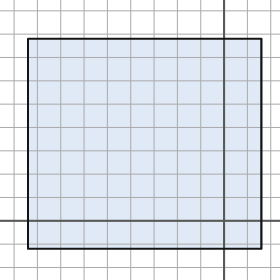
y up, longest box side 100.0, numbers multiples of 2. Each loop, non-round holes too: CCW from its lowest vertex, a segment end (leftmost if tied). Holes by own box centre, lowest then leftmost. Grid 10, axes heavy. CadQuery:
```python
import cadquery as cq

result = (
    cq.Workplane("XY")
    .moveTo(-84.0, -12.0)
    .lineTo(16.0, -12.0)
    .lineTo(16.0, 78.0)
    .lineTo(-84.0, 78.0)
    .close()
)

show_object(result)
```